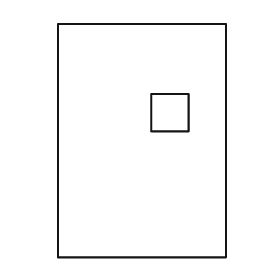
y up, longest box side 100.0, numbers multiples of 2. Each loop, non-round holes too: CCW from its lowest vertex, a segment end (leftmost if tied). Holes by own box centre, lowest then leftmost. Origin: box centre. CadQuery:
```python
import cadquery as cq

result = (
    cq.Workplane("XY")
    .moveTo(-36.0, -50.0)
    .lineTo(36.0, -50.0)
    .lineTo(36.0, 50.0)
    .lineTo(-36.0, 50.0)
    .close()
    .moveTo(4.0, 4.0)
    .lineTo(20.0, 4.0)
    .lineTo(20.0, 20.0)
    .lineTo(4.0, 20.0)
    .close()
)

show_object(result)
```